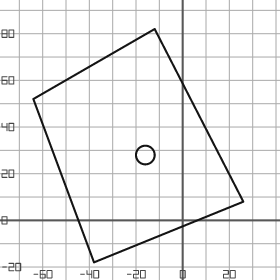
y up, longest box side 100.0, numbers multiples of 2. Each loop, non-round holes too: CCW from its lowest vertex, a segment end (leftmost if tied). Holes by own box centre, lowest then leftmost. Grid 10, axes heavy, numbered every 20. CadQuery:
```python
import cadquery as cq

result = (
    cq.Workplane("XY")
    .moveTo(-38.0, -18.0)
    .lineTo(26.0, 8.0)
    .lineTo(-12.0, 82.0)
    .lineTo(-64.0, 52.0)
    .close()
    .moveTo(-16.0, 28.0)
    .circle(4.0)
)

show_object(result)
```